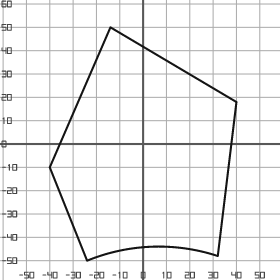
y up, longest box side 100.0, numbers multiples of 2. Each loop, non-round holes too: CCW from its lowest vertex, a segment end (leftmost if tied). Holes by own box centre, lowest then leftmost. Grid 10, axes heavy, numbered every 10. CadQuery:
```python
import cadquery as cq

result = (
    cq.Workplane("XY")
    .moveTo(-24.0, -50.0)
    .threePointArc((4.0, -44.0), (32.0, -48.0))
    .lineTo(40.0, 18.0)
    .lineTo(-14.0, 50.0)
    .lineTo(-40.0, -10.0)
    .close()
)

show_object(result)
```